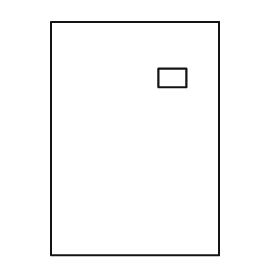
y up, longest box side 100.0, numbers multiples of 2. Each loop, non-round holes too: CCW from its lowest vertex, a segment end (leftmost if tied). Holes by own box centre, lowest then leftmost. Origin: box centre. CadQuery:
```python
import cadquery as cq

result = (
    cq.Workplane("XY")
    .moveTo(-36.0, -50.0)
    .lineTo(36.0, -50.0)
    .lineTo(36.0, 50.0)
    .lineTo(-36.0, 50.0)
    .close()
    .moveTo(10.0, 22.0)
    .lineTo(22.0, 22.0)
    .lineTo(22.0, 30.0)
    .lineTo(10.0, 30.0)
    .close()
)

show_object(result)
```